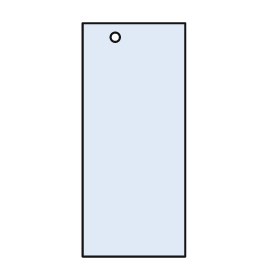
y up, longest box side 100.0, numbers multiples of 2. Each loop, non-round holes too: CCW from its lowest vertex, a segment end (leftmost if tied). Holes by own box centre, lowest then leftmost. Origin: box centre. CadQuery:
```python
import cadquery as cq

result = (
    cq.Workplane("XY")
    .moveTo(-22.0, -50.0)
    .lineTo(22.0, -50.0)
    .lineTo(22.0, 50.0)
    .lineTo(-22.0, 50.0)
    .close()
    .moveTo(-8.0, 44.0)
    .circle(2.0)
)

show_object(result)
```